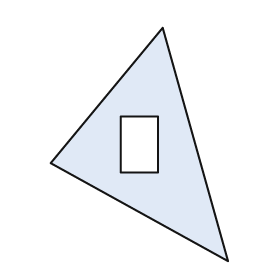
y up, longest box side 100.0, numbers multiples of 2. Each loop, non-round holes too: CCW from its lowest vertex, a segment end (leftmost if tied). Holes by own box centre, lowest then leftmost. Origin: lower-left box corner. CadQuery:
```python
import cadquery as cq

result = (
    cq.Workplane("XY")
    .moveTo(76.0, 0.0)
    .lineTo(48.0, 100.0)
    .lineTo(0.0, 42.0)
    .close()
    .moveTo(30.0, 38.0)
    .lineTo(46.0, 38.0)
    .lineTo(46.0, 62.0)
    .lineTo(30.0, 62.0)
    .close()
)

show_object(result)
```